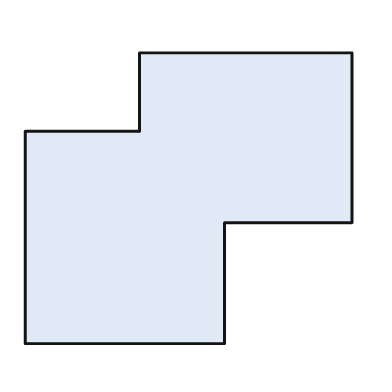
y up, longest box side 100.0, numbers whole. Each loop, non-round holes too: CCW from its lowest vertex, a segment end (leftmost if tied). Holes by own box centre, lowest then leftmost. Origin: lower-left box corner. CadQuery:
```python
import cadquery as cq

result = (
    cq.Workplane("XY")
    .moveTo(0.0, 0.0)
    .lineTo(61.0, 0.0)
    .lineTo(61.0, 37.0)
    .lineTo(100.0, 37.0)
    .lineTo(100.0, 89.0)
    .lineTo(35.0, 89.0)
    .lineTo(35.0, 65.0)
    .lineTo(0.0, 65.0)
    .close()
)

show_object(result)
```